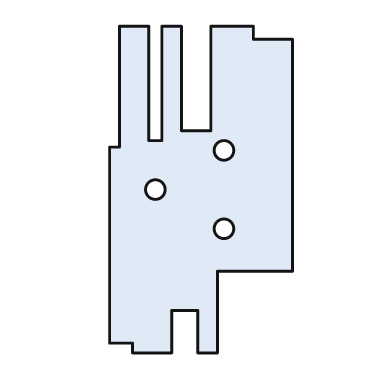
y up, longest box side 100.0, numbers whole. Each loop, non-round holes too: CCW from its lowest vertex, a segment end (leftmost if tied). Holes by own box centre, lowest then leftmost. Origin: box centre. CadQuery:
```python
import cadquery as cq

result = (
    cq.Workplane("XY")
    .moveTo(-21.0, -50.0)
    .lineTo(-9.0, -50.0)
    .lineTo(-9.0, -37.0)
    .lineTo(-1.0, -37.0)
    .lineTo(-1.0, -50.0)
    .lineTo(5.0, -50.0)
    .lineTo(5.0, -25.0)
    .lineTo(28.0, -25.0)
    .lineTo(28.0, 46.0)
    .lineTo(16.0, 46.0)
    .lineTo(16.0, 50.0)
    .lineTo(3.0, 50.0)
    .lineTo(3.0, 18.0)
    .lineTo(-6.0, 18.0)
    .lineTo(-6.0, 50.0)
    .lineTo(-12.0, 50.0)
    .lineTo(-12.0, 15.0)
    .lineTo(-16.0, 15.0)
    .lineTo(-16.0, 50.0)
    .lineTo(-25.0, 50.0)
    .lineTo(-25.0, 13.0)
    .lineTo(-28.0, 13.0)
    .lineTo(-28.0, -47.0)
    .lineTo(-21.0, -47.0)
    .close()
    .moveTo(7.0, -12.0)
    .circle(3.0)
    .moveTo(-14.0, 0.0)
    .circle(3.0)
    .moveTo(7.0, 12.0)
    .circle(3.0)
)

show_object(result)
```